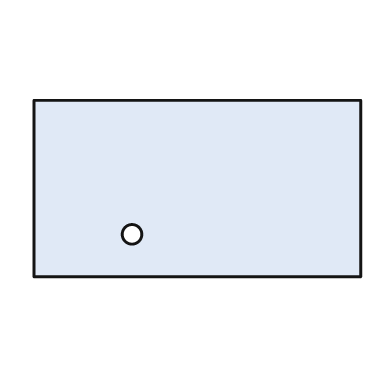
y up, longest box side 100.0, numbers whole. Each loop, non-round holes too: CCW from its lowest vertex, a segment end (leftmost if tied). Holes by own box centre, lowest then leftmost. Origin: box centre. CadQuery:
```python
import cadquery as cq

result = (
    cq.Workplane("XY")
    .moveTo(-50.0, -27.0)
    .lineTo(50.0, -27.0)
    .lineTo(50.0, 27.0)
    .lineTo(-50.0, 27.0)
    .close()
    .moveTo(-20.0, -14.0)
    .circle(3.0)
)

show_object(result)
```